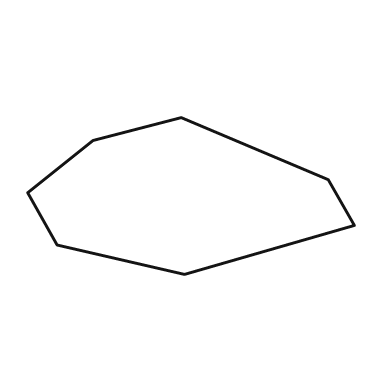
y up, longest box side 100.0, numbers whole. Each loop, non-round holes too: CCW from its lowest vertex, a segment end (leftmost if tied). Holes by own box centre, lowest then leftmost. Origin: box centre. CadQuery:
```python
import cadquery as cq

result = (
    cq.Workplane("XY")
    .moveTo(-2.0, -24.0)
    .lineTo(50.0, -9.0)
    .lineTo(42.0, 5.0)
    .lineTo(-3.0, 24.0)
    .lineTo(-30.0, 17.0)
    .lineTo(-50.0, 1.0)
    .lineTo(-41.0, -15.0)
    .close()
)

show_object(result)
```